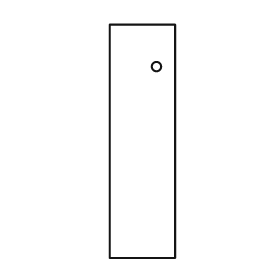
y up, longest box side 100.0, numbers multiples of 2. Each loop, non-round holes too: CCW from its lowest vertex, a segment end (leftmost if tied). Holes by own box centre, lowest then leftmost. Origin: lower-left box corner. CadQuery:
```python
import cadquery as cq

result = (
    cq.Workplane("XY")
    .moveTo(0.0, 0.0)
    .lineTo(28.0, 0.0)
    .lineTo(28.0, 100.0)
    .lineTo(0.0, 100.0)
    .close()
    .moveTo(20.0, 82.0)
    .circle(2.0)
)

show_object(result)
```